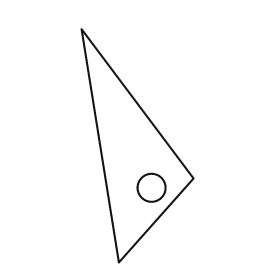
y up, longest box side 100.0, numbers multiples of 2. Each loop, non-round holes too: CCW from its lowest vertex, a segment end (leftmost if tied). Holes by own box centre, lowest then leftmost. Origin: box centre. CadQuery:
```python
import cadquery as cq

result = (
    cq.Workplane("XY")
    .moveTo(-8.0, -50.0)
    .lineTo(24.0, -14.0)
    .lineTo(-24.0, 50.0)
    .close()
    .moveTo(6.0, -18.0)
    .circle(6.0)
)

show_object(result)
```